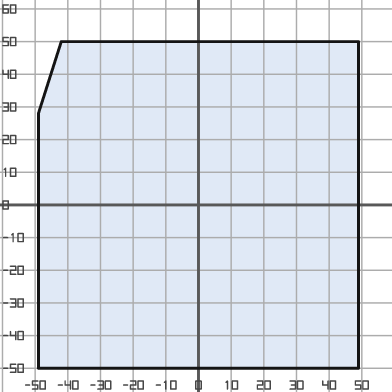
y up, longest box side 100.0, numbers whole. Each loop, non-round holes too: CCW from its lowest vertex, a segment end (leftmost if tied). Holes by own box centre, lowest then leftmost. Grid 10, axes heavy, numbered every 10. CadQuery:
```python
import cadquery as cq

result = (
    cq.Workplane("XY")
    .moveTo(-49.0, -50.0)
    .lineTo(49.0, -50.0)
    .lineTo(49.0, 50.0)
    .lineTo(-42.0, 50.0)
    .lineTo(-49.0, 28.0)
    .close()
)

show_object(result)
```